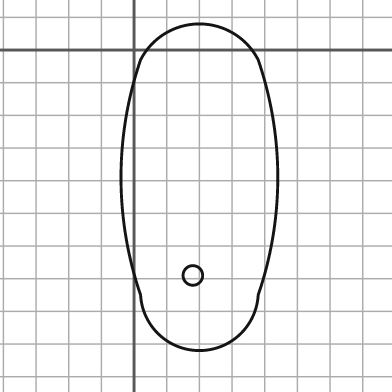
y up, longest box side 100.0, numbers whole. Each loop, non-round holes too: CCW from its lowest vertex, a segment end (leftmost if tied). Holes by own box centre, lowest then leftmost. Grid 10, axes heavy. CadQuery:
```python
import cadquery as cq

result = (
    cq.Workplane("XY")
    .moveTo(2.0, -75.0)
    .threePointArc((20.0, -92.0), (38.0, -75.0))
    .threePointArc((44.0, -39.0), (38.0, -3.0))
    .threePointArc((20.0, 8.0), (2.0, -3.0))
    .threePointArc((-4.0, -39.0), (2.0, -75.0))
    .close()
    .moveTo(18.0, -69.0)
    .circle(3.0)
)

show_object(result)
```